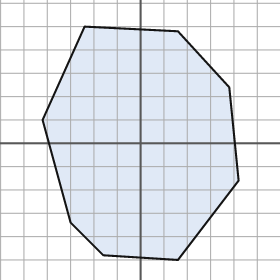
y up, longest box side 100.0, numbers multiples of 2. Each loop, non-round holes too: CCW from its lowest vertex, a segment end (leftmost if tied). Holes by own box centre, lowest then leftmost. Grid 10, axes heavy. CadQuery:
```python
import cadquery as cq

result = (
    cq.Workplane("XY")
    .moveTo(16.0, -50.0)
    .lineTo(42.0, -16.0)
    .lineTo(38.0, 24.0)
    .lineTo(16.0, 48.0)
    .lineTo(-24.0, 50.0)
    .lineTo(-42.0, 10.0)
    .lineTo(-30.0, -34.0)
    .lineTo(-16.0, -48.0)
    .close()
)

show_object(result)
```